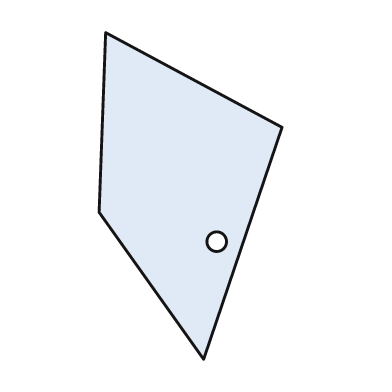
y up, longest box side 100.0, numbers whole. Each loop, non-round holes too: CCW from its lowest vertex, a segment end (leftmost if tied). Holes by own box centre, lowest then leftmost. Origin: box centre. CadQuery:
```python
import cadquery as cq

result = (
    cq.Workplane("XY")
    .moveTo(4.0, -50.0)
    .lineTo(28.0, 21.0)
    .lineTo(-26.0, 50.0)
    .lineTo(-28.0, -5.0)
    .close()
    .moveTo(8.0, -14.0)
    .circle(3.0)
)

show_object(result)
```